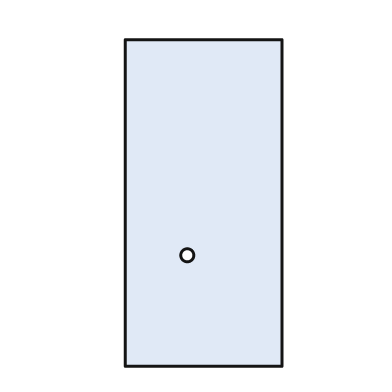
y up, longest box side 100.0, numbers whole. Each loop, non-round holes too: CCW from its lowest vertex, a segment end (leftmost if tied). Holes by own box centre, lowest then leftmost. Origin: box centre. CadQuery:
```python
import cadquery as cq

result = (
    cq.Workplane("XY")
    .moveTo(-24.0, -50.0)
    .lineTo(24.0, -50.0)
    .lineTo(24.0, 50.0)
    .lineTo(-24.0, 50.0)
    .close()
    .moveTo(-5.0, -16.0)
    .circle(2.0)
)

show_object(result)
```